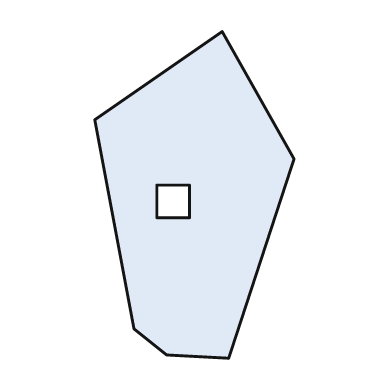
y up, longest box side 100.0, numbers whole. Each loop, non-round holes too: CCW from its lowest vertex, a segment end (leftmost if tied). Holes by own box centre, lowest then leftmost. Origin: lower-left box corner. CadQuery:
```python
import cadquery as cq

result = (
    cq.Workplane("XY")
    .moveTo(41.0, 0.0)
    .lineTo(61.0, 61.0)
    .lineTo(39.0, 100.0)
    .lineTo(0.0, 73.0)
    .lineTo(12.0, 9.0)
    .lineTo(22.0, 1.0)
    .close()
    .moveTo(19.0, 43.0)
    .lineTo(29.0, 43.0)
    .lineTo(29.0, 53.0)
    .lineTo(19.0, 53.0)
    .close()
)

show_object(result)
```